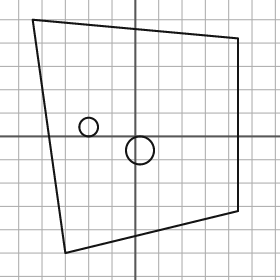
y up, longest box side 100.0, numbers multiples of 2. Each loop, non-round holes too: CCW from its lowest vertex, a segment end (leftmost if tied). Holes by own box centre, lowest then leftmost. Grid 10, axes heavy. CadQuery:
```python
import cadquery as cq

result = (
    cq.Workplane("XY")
    .moveTo(-30.0, -50.0)
    .lineTo(44.0, -32.0)
    .lineTo(44.0, 42.0)
    .lineTo(-44.0, 50.0)
    .close()
    .moveTo(2.0, -6.0)
    .circle(6.0)
    .moveTo(-20.0, 4.0)
    .circle(4.0)
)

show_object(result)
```